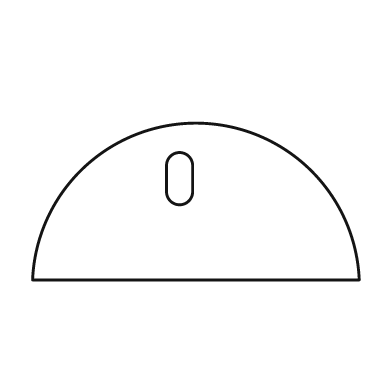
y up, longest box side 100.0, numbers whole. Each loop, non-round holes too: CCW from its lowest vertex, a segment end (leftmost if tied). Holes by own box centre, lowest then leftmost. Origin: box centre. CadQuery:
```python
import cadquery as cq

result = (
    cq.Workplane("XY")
    .moveTo(-50.0, -24.0)
    .lineTo(50.0, -24.0)
    .threePointArc((0.0, 24.0), (-50.0, -24.0))
    .close()
    .moveTo(-9.0, 3.0)
    .threePointArc((-5.0, -1.0), (-1.0, 3.0))
    .lineTo(-1.0, 11.0)
    .threePointArc((-5.0, 15.0), (-9.0, 11.0))
    .close()
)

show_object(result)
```